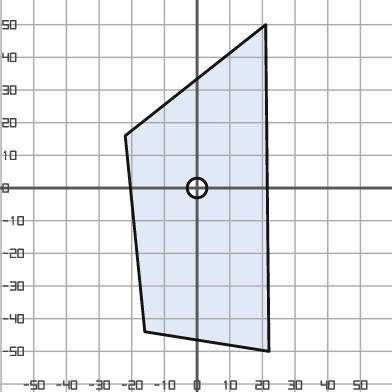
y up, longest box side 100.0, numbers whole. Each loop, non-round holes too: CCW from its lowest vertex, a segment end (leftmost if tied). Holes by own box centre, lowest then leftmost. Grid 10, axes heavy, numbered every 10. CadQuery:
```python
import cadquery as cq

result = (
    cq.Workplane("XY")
    .moveTo(22.0, -50.0)
    .lineTo(21.0, 50.0)
    .lineTo(-22.0, 16.0)
    .lineTo(-16.0, -44.0)
    .close()
    .moveTo(0.0, 0.0)
    .circle(3.0)
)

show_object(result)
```